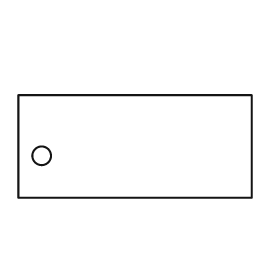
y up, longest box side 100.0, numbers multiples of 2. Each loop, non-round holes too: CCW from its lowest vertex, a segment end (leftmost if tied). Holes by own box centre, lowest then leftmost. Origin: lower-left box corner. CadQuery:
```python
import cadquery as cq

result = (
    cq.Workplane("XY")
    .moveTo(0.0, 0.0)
    .lineTo(100.0, 0.0)
    .lineTo(100.0, 44.0)
    .lineTo(0.0, 44.0)
    .close()
    .moveTo(10.0, 18.0)
    .circle(4.0)
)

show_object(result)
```